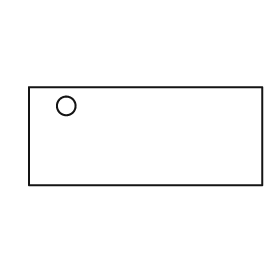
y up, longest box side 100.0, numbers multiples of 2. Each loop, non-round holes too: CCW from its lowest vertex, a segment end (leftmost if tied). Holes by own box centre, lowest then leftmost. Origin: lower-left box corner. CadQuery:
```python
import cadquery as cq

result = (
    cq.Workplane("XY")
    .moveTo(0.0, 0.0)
    .lineTo(100.0, 0.0)
    .lineTo(100.0, 42.0)
    .lineTo(0.0, 42.0)
    .close()
    .moveTo(16.0, 34.0)
    .circle(4.0)
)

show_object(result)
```